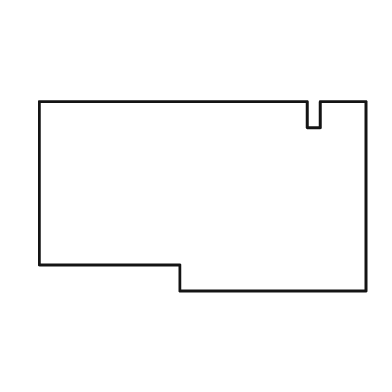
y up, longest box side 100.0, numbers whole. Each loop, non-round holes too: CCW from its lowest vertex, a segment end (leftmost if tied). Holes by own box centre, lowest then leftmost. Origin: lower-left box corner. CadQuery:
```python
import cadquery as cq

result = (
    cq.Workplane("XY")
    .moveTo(43.0, 0.0)
    .lineTo(100.0, 0.0)
    .lineTo(100.0, 58.0)
    .lineTo(86.0, 58.0)
    .lineTo(86.0, 50.0)
    .lineTo(82.0, 50.0)
    .lineTo(82.0, 58.0)
    .lineTo(0.0, 58.0)
    .lineTo(0.0, 8.0)
    .lineTo(43.0, 8.0)
    .close()
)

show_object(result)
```